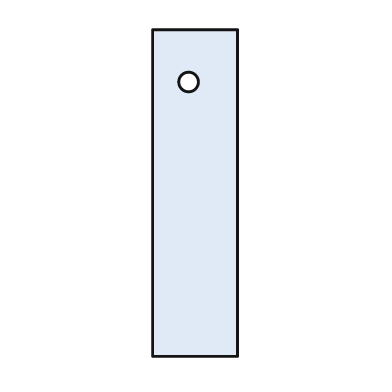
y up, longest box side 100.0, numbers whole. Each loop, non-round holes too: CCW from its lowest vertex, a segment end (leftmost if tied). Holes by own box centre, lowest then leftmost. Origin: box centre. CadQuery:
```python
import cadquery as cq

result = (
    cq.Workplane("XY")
    .moveTo(-13.0, -50.0)
    .lineTo(13.0, -50.0)
    .lineTo(13.0, 50.0)
    .lineTo(-13.0, 50.0)
    .close()
    .moveTo(-2.0, 34.0)
    .circle(3.0)
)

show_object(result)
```